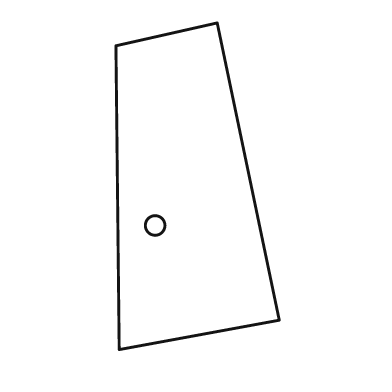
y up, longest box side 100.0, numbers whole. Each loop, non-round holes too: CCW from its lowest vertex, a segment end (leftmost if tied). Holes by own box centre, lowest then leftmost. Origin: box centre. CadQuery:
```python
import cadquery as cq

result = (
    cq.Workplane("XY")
    .moveTo(-24.0, -50.0)
    .lineTo(25.0, -41.0)
    .lineTo(6.0, 50.0)
    .lineTo(-25.0, 43.0)
    .close()
    .moveTo(-13.0, -12.0)
    .circle(3.0)
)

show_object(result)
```